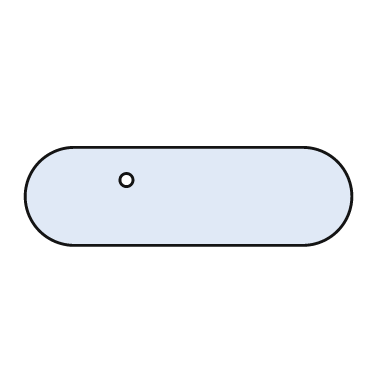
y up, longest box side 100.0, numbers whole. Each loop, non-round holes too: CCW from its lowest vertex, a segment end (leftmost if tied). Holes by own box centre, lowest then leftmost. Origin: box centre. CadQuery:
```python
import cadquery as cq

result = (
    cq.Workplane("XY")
    .moveTo(-35.0, -15.0)
    .lineTo(35.0, -15.0)
    .threePointArc((50.0, 0.0), (35.0, 15.0))
    .lineTo(-35.0, 15.0)
    .threePointArc((-50.0, 0.0), (-35.0, -15.0))
    .close()
    .moveTo(-19.0, 5.0)
    .circle(2.0)
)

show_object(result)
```